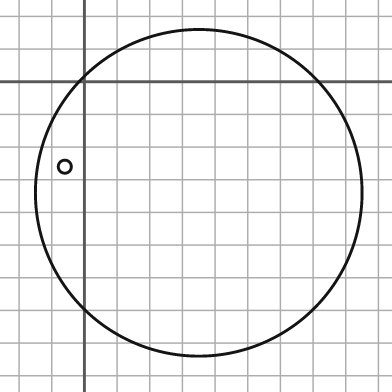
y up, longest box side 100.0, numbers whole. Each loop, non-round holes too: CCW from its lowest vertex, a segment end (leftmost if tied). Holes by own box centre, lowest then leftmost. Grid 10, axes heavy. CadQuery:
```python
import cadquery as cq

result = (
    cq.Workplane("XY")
    .moveTo(35.0, -34.0)
    .circle(50.0)
    .moveTo(-6.0, -26.0)
    .circle(2.0)
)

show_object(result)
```